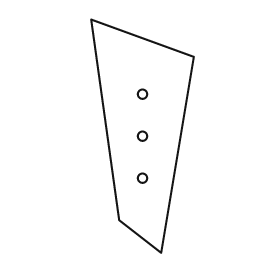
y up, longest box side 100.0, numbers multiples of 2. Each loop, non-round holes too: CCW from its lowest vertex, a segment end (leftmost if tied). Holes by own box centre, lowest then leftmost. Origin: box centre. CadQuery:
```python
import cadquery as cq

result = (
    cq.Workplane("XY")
    .moveTo(8.0, -50.0)
    .lineTo(22.0, 34.0)
    .lineTo(-22.0, 50.0)
    .lineTo(-10.0, -36.0)
    .close()
    .moveTo(0.0, -18.0)
    .circle(2.0)
    .moveTo(0.0, 0.0)
    .circle(2.0)
    .moveTo(0.0, 18.0)
    .circle(2.0)
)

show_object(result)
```